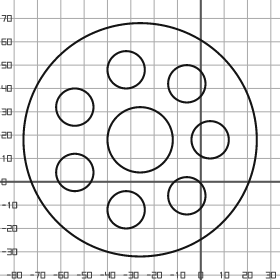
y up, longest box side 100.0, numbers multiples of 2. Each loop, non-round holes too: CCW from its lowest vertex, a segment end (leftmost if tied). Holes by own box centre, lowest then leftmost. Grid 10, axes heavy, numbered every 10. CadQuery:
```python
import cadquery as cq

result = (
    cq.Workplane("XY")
    .moveTo(-26.0, 18.0)
    .circle(50.0)
    .moveTo(-32.0, -12.0)
    .circle(8.0)
    .moveTo(-6.0, -6.0)
    .circle(8.0)
    .moveTo(-54.0, 4.0)
    .circle(8.0)
    .moveTo(-26.0, 18.0)
    .circle(14.0)
    .moveTo(4.0, 18.0)
    .circle(8.0)
    .moveTo(-54.0, 32.0)
    .circle(8.0)
    .moveTo(-6.0, 42.0)
    .circle(8.0)
    .moveTo(-32.0, 48.0)
    .circle(8.0)
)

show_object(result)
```